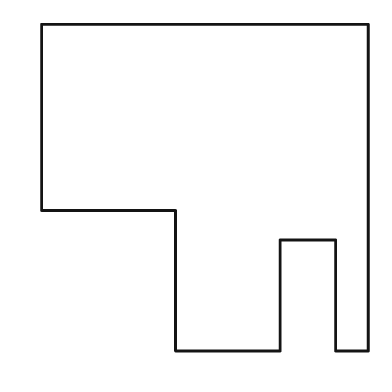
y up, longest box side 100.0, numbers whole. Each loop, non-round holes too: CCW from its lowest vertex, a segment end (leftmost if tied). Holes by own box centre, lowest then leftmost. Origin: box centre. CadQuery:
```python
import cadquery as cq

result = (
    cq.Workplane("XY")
    .moveTo(-9.0, -50.0)
    .lineTo(23.0, -50.0)
    .lineTo(23.0, -16.0)
    .lineTo(40.0, -16.0)
    .lineTo(40.0, -50.0)
    .lineTo(50.0, -50.0)
    .lineTo(50.0, 50.0)
    .lineTo(-50.0, 50.0)
    .lineTo(-50.0, -7.0)
    .lineTo(-9.0, -7.0)
    .close()
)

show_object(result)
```